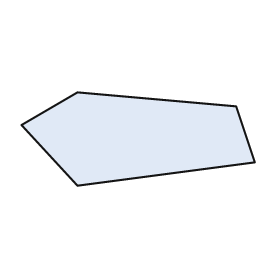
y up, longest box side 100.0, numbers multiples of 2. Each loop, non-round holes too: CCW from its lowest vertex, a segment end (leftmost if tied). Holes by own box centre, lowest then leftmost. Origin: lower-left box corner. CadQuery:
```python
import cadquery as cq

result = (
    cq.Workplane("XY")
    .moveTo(24.0, 0.0)
    .lineTo(100.0, 10.0)
    .lineTo(92.0, 34.0)
    .lineTo(24.0, 40.0)
    .lineTo(0.0, 26.0)
    .close()
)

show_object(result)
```